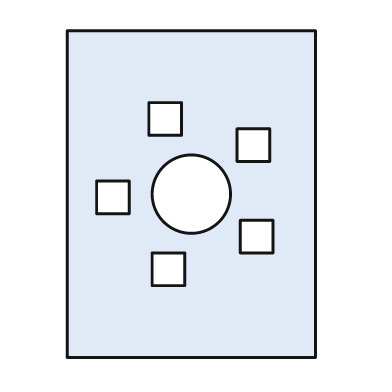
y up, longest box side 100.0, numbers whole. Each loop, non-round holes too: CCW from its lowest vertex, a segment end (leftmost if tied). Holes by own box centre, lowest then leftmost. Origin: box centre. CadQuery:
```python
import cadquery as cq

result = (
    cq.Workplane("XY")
    .moveTo(-38.0, -50.0)
    .lineTo(38.0, -50.0)
    .lineTo(38.0, 50.0)
    .lineTo(-38.0, 50.0)
    .close()
    .moveTo(-12.0, -28.0)
    .lineTo(-2.0, -28.0)
    .lineTo(-2.0, -18.0)
    .lineTo(-12.0, -18.0)
    .close()
    .moveTo(15.0, -18.0)
    .lineTo(25.0, -18.0)
    .lineTo(25.0, -8.0)
    .lineTo(15.0, -8.0)
    .close()
    .moveTo(-29.0, -6.0)
    .lineTo(-19.0, -6.0)
    .lineTo(-19.0, 4.0)
    .lineTo(-29.0, 4.0)
    .close()
    .moveTo(0.0, 0.0)
    .circle(12.0)
    .moveTo(14.0, 10.0)
    .lineTo(24.0, 10.0)
    .lineTo(24.0, 20.0)
    .lineTo(14.0, 20.0)
    .close()
    .moveTo(-13.0, 18.0)
    .lineTo(-3.0, 18.0)
    .lineTo(-3.0, 28.0)
    .lineTo(-13.0, 28.0)
    .close()
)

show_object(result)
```